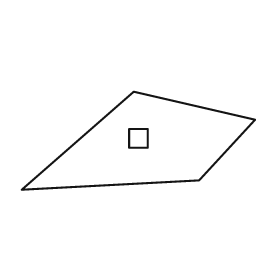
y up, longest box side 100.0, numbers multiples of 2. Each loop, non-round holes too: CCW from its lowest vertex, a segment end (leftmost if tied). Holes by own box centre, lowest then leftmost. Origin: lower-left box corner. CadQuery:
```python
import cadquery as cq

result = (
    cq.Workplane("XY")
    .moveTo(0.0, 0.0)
    .lineTo(76.0, 4.0)
    .lineTo(100.0, 30.0)
    .lineTo(48.0, 42.0)
    .close()
    .moveTo(46.0, 18.0)
    .lineTo(54.0, 18.0)
    .lineTo(54.0, 26.0)
    .lineTo(46.0, 26.0)
    .close()
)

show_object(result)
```